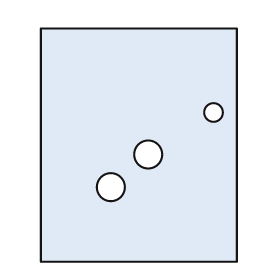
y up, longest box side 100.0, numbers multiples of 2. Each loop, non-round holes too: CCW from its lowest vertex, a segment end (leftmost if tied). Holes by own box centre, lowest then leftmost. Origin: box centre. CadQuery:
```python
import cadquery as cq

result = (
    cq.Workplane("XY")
    .moveTo(-42.0, -50.0)
    .lineTo(42.0, -50.0)
    .lineTo(42.0, 50.0)
    .lineTo(-42.0, 50.0)
    .close()
    .moveTo(-12.0, -18.0)
    .circle(6.0)
    .moveTo(4.0, -4.0)
    .circle(6.0)
    .moveTo(32.0, 14.0)
    .circle(4.0)
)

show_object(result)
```